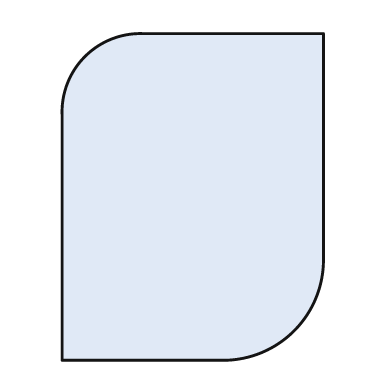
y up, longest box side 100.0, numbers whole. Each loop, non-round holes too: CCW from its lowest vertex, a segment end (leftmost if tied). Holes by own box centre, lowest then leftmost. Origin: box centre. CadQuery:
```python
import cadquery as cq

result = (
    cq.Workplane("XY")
    .moveTo(-40.0, -50.0)
    .lineTo(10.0, -50.0)
    .threePointArc((31.0, -41.0), (40.0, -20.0))
    .lineTo(40.0, 50.0)
    .lineTo(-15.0, 50.0)
    .threePointArc((-33.0, 43.0), (-40.0, 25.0))
    .close()
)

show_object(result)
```